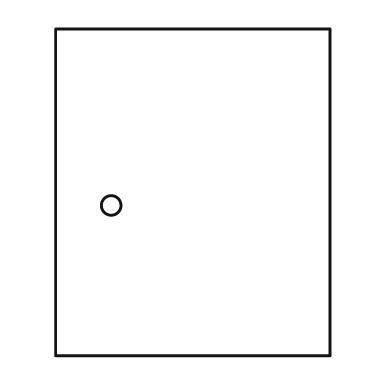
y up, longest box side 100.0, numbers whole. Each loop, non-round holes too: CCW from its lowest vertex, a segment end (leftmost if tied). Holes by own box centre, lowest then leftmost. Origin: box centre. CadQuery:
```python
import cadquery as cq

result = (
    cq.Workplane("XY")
    .moveTo(-42.0, -50.0)
    .lineTo(42.0, -50.0)
    .lineTo(42.0, 50.0)
    .lineTo(-42.0, 50.0)
    .close()
    .moveTo(-25.0, -4.0)
    .circle(3.0)
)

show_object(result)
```